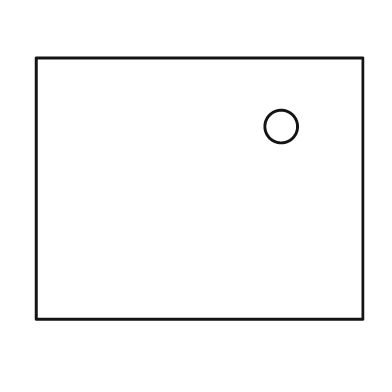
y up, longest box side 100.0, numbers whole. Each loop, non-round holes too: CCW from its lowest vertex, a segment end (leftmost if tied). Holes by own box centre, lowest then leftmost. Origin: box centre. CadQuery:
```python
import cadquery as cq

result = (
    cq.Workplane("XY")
    .moveTo(-50.0, -40.0)
    .lineTo(50.0, -40.0)
    .lineTo(50.0, 40.0)
    .lineTo(-50.0, 40.0)
    .close()
    .moveTo(25.0, 19.0)
    .circle(5.0)
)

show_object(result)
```